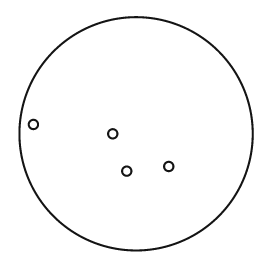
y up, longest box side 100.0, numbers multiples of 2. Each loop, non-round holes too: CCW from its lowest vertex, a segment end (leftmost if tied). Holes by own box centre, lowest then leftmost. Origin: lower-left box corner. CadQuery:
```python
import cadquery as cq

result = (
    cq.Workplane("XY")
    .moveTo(50.0, 50.0)
    .circle(50.0)
    .moveTo(46.0, 34.0)
    .circle(2.0)
    .moveTo(64.0, 36.0)
    .circle(2.0)
    .moveTo(40.0, 50.0)
    .circle(2.0)
    .moveTo(6.0, 54.0)
    .circle(2.0)
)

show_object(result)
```